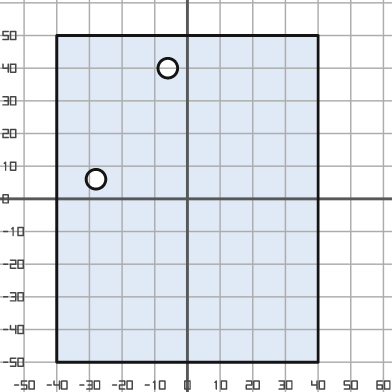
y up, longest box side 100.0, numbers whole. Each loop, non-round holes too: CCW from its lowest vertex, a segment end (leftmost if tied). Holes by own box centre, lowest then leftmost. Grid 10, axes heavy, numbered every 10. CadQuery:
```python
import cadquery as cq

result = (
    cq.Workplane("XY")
    .moveTo(-40.0, -50.0)
    .lineTo(40.0, -50.0)
    .lineTo(40.0, 50.0)
    .lineTo(-40.0, 50.0)
    .close()
    .moveTo(-28.0, 6.0)
    .circle(3.0)
    .moveTo(-6.0, 40.0)
    .circle(3.0)
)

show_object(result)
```